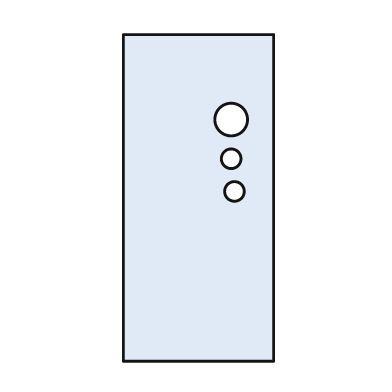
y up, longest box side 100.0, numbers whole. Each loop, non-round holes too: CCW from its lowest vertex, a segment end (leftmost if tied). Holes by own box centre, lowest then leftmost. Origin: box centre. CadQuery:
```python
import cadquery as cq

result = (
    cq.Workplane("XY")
    .moveTo(-23.0, -50.0)
    .lineTo(23.0, -50.0)
    .lineTo(23.0, 50.0)
    .lineTo(-23.0, 50.0)
    .close()
    .moveTo(11.0, 2.0)
    .circle(3.0)
    .moveTo(10.0, 12.0)
    .circle(3.0)
    .moveTo(10.0, 24.0)
    .circle(5.0)
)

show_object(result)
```